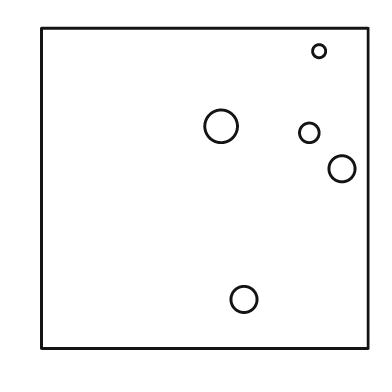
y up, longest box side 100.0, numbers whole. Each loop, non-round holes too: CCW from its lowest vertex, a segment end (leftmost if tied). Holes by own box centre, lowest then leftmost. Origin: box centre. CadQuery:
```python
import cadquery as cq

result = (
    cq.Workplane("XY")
    .moveTo(-50.0, -49.0)
    .lineTo(50.0, -49.0)
    .lineTo(50.0, 49.0)
    .lineTo(-50.0, 49.0)
    .close()
    .moveTo(12.0, -34.0)
    .circle(4.0)
    .moveTo(42.0, 6.0)
    .circle(4.0)
    .moveTo(32.0, 17.0)
    .circle(3.0)
    .moveTo(5.0, 19.0)
    .circle(5.0)
    .moveTo(35.0, 42.0)
    .circle(2.0)
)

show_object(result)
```